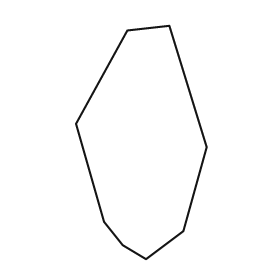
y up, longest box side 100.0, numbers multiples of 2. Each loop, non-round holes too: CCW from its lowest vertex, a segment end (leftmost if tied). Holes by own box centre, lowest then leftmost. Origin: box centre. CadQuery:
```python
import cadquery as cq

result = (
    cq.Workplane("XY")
    .moveTo(2.0, -50.0)
    .lineTo(18.0, -38.0)
    .lineTo(28.0, -2.0)
    .lineTo(12.0, 50.0)
    .lineTo(-6.0, 48.0)
    .lineTo(-28.0, 8.0)
    .lineTo(-16.0, -34.0)
    .lineTo(-8.0, -44.0)
    .close()
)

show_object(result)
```